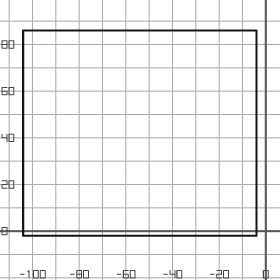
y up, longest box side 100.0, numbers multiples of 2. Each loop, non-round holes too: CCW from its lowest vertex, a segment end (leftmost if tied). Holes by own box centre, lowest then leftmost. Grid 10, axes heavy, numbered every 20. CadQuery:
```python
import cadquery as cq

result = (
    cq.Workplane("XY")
    .moveTo(-104.0, -2.0)
    .lineTo(-4.0, -2.0)
    .lineTo(-4.0, 86.0)
    .lineTo(-104.0, 86.0)
    .close()
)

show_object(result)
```